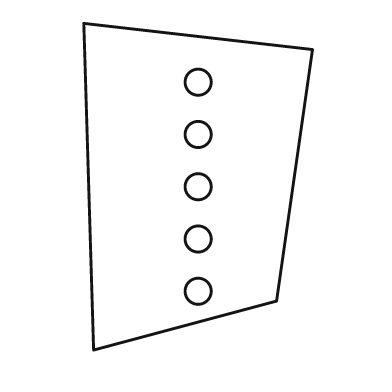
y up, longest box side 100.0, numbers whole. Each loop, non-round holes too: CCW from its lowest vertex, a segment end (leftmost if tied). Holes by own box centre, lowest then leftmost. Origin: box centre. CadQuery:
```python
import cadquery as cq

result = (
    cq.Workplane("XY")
    .moveTo(-32.0, -50.0)
    .lineTo(24.0, -35.0)
    .lineTo(35.0, 42.0)
    .lineTo(-35.0, 50.0)
    .close()
    .moveTo(0.0, -32.0)
    .circle(4.0)
    .moveTo(0.0, -16.0)
    .circle(4.0)
    .moveTo(0.0, 0.0)
    .circle(4.0)
    .moveTo(0.0, 16.0)
    .circle(4.0)
    .moveTo(0.0, 32.0)
    .circle(4.0)
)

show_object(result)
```